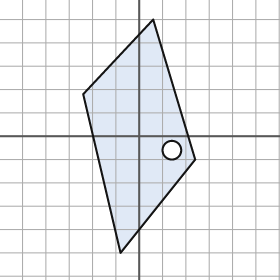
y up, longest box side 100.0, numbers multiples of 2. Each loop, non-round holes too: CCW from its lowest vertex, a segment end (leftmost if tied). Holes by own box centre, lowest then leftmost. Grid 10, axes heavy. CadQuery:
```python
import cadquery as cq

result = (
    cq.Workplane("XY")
    .moveTo(-8.0, -50.0)
    .lineTo(24.0, -10.0)
    .lineTo(6.0, 50.0)
    .lineTo(-24.0, 18.0)
    .close()
    .moveTo(14.0, -6.0)
    .circle(4.0)
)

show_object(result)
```